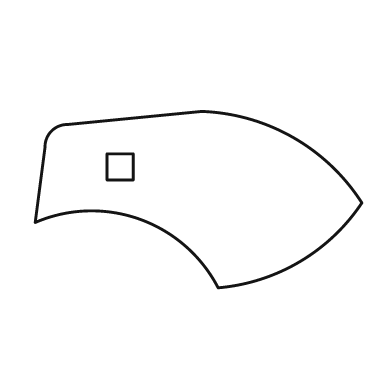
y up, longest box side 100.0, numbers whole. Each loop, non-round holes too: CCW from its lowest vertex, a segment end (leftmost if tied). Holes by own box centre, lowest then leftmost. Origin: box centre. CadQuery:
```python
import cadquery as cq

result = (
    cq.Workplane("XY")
    .moveTo(6.0, -27.0)
    .threePointArc((31.0, -19.0), (50.0, -1.0))
    .threePointArc((29.0, 19.0), (1.0, 27.0))
    .lineTo(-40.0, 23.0)
    .threePointArc((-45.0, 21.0), (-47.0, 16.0))
    .lineTo(-50.0, -7.0)
    .threePointArc((-18.0, -6.0), (6.0, -27.0))
    .close()
    .moveTo(-28.0, 6.0)
    .lineTo(-20.0, 6.0)
    .lineTo(-20.0, 14.0)
    .lineTo(-28.0, 14.0)
    .close()
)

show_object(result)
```